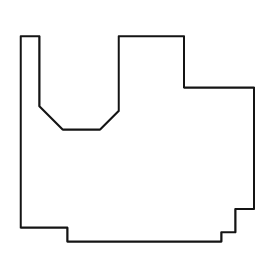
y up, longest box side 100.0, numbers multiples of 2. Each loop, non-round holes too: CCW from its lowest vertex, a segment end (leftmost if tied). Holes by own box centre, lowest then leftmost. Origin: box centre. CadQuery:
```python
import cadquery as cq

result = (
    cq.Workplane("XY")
    .moveTo(-30.0, -44.0)
    .lineTo(36.0, -44.0)
    .lineTo(36.0, -40.0)
    .lineTo(42.0, -40.0)
    .lineTo(42.0, -30.0)
    .lineTo(50.0, -30.0)
    .lineTo(50.0, 22.0)
    .lineTo(20.0, 22.0)
    .lineTo(20.0, 44.0)
    .lineTo(-8.0, 44.0)
    .lineTo(-8.0, 12.0)
    .lineTo(-16.0, 4.0)
    .lineTo(-32.0, 4.0)
    .lineTo(-42.0, 14.0)
    .lineTo(-42.0, 44.0)
    .lineTo(-50.0, 44.0)
    .lineTo(-50.0, -38.0)
    .lineTo(-30.0, -38.0)
    .close()
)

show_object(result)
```